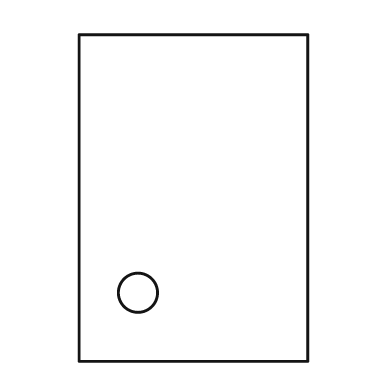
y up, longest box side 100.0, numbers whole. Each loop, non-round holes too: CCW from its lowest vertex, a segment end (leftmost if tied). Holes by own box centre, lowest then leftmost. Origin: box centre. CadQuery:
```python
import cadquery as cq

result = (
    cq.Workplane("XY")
    .moveTo(-35.0, -50.0)
    .lineTo(35.0, -50.0)
    .lineTo(35.0, 50.0)
    .lineTo(-35.0, 50.0)
    .close()
    .moveTo(-17.0, -29.0)
    .circle(6.0)
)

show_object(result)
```